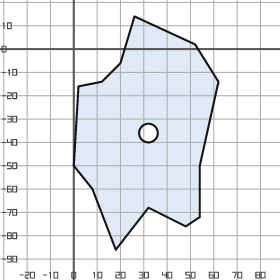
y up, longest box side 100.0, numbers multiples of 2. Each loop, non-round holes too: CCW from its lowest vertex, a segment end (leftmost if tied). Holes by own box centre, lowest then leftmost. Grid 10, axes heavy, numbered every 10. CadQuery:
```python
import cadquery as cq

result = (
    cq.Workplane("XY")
    .moveTo(18.0, -86.0)
    .lineTo(32.0, -68.0)
    .lineTo(48.0, -76.0)
    .lineTo(54.0, -72.0)
    .lineTo(54.0, -50.0)
    .lineTo(62.0, -14.0)
    .lineTo(52.0, 2.0)
    .lineTo(26.0, 14.0)
    .lineTo(20.0, -6.0)
    .lineTo(12.0, -14.0)
    .lineTo(2.0, -16.0)
    .lineTo(0.0, -50.0)
    .lineTo(8.0, -60.0)
    .close()
    .moveTo(32.0, -36.0)
    .circle(4.0)
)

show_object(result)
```